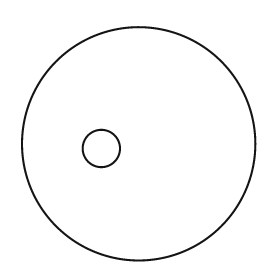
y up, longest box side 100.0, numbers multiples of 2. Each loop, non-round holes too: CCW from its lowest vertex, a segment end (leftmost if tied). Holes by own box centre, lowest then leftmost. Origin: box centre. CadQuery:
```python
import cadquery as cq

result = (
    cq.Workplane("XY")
    .moveTo(0.0, 0.0)
    .circle(50.0)
    .moveTo(-16.0, -2.0)
    .circle(8.0)
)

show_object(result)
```